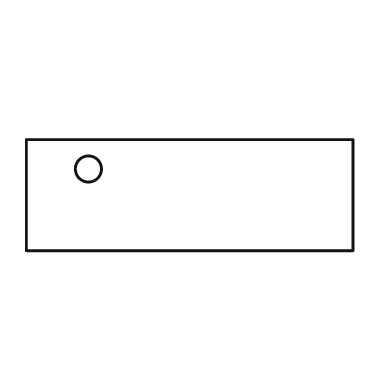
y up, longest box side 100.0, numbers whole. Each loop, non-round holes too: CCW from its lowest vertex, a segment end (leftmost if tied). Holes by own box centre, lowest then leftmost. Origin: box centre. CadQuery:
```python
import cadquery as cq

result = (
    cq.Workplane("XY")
    .moveTo(-50.0, -17.0)
    .lineTo(50.0, -17.0)
    .lineTo(50.0, 17.0)
    .lineTo(-50.0, 17.0)
    .close()
    .moveTo(-31.0, 8.0)
    .circle(4.0)
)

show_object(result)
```